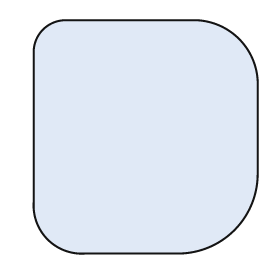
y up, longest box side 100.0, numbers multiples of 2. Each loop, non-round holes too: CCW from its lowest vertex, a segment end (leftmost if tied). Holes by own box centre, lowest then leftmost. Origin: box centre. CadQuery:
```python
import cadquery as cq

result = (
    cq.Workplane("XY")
    .moveTo(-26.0, -50.0)
    .lineTo(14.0, -50.0)
    .threePointArc((38.0, -40.0), (48.0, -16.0))
    .lineTo(48.0, 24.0)
    .threePointArc((40.0, 42.0), (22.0, 50.0))
    .lineTo(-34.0, 50.0)
    .threePointArc((-44.0, 46.0), (-48.0, 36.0))
    .lineTo(-48.0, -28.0)
    .threePointArc((-42.0, -44.0), (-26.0, -50.0))
    .close()
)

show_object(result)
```